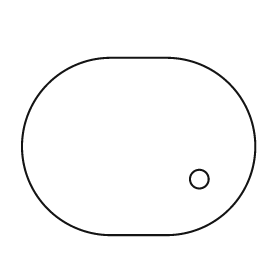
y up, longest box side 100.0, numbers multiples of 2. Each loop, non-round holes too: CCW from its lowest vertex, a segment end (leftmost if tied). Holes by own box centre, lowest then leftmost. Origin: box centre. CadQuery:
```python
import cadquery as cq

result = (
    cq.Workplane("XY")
    .moveTo(-12.0, -38.0)
    .lineTo(12.0, -38.0)
    .threePointArc((50.0, 0.0), (12.0, 38.0))
    .lineTo(-12.0, 38.0)
    .threePointArc((-50.0, 0.0), (-12.0, -38.0))
    .close()
    .moveTo(26.0, -14.0)
    .circle(4.0)
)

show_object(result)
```